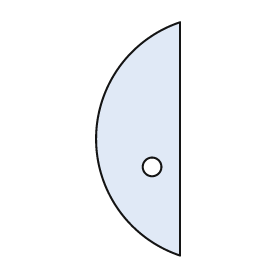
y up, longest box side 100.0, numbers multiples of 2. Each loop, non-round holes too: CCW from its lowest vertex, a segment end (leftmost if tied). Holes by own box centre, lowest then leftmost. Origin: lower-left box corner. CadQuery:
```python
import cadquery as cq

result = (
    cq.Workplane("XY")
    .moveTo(36.0, 0.0)
    .lineTo(36.0, 100.0)
    .threePointArc((0.0, 50.0), (36.0, 0.0))
    .close()
    .moveTo(24.0, 38.0)
    .circle(4.0)
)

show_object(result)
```